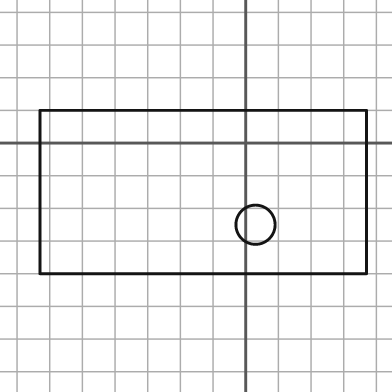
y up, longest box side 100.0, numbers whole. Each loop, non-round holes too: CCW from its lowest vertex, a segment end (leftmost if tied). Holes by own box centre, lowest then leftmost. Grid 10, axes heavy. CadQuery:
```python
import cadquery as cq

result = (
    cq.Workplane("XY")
    .moveTo(-63.0, -40.0)
    .lineTo(37.0, -40.0)
    .lineTo(37.0, 10.0)
    .lineTo(-63.0, 10.0)
    .close()
    .moveTo(3.0, -25.0)
    .circle(6.0)
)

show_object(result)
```